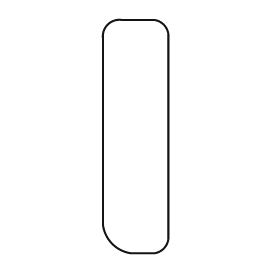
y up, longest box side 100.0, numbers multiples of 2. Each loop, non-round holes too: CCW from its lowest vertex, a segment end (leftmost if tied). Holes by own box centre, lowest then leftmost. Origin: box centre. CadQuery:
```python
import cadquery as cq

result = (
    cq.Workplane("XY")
    .moveTo(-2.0, -50.0)
    .lineTo(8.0, -50.0)
    .threePointArc((12.0, -48.0), (14.0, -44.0))
    .lineTo(14.0, 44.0)
    .threePointArc((12.0, 48.0), (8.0, 50.0))
    .lineTo(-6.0, 50.0)
    .threePointArc((-12.0, 48.0), (-14.0, 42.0))
    .lineTo(-14.0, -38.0)
    .threePointArc((-10.0, -46.0), (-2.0, -50.0))
    .close()
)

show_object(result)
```